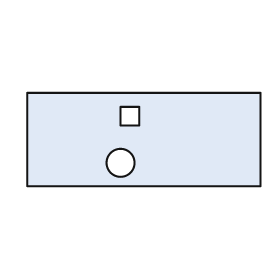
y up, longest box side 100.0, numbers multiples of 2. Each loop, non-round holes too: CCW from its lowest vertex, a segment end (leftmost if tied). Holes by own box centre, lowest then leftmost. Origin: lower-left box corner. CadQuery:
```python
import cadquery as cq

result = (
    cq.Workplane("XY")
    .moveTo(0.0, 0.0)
    .lineTo(100.0, 0.0)
    .lineTo(100.0, 40.0)
    .lineTo(0.0, 40.0)
    .close()
    .moveTo(40.0, 10.0)
    .circle(6.0)
    .moveTo(40.0, 26.0)
    .lineTo(48.0, 26.0)
    .lineTo(48.0, 34.0)
    .lineTo(40.0, 34.0)
    .close()
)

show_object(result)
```